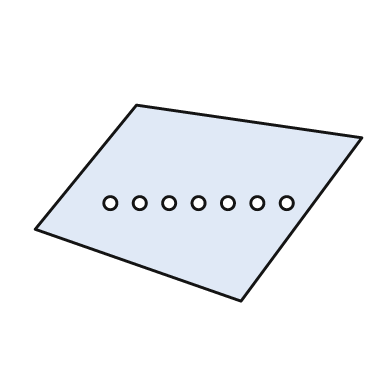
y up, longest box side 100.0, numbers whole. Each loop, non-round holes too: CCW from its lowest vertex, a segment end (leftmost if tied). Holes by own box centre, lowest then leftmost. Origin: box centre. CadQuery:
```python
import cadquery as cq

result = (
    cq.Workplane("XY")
    .moveTo(13.0, -30.0)
    .lineTo(50.0, 20.0)
    .lineTo(-19.0, 30.0)
    .lineTo(-50.0, -8.0)
    .close()
    .moveTo(-27.0, 0.0)
    .circle(2.0)
    .moveTo(-18.0, 0.0)
    .circle(2.0)
    .moveTo(-9.0, 0.0)
    .circle(2.0)
    .moveTo(0.0, 0.0)
    .circle(2.0)
    .moveTo(9.0, 0.0)
    .circle(2.0)
    .moveTo(18.0, 0.0)
    .circle(2.0)
    .moveTo(27.0, 0.0)
    .circle(2.0)
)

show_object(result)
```